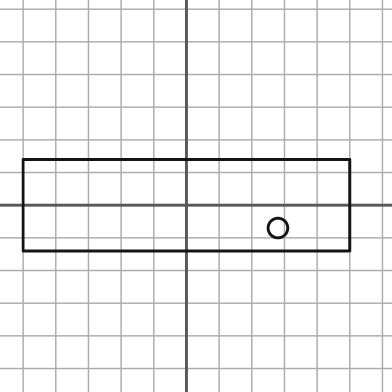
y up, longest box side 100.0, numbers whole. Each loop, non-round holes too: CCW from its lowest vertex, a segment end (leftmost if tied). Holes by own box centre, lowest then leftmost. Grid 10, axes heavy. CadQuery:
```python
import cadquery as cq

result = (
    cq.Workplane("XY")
    .moveTo(-50.0, -14.0)
    .lineTo(50.0, -14.0)
    .lineTo(50.0, 14.0)
    .lineTo(-50.0, 14.0)
    .close()
    .moveTo(28.0, -7.0)
    .circle(3.0)
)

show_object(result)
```